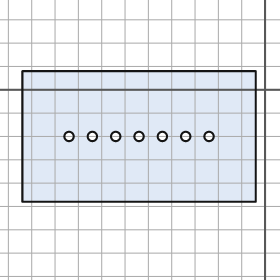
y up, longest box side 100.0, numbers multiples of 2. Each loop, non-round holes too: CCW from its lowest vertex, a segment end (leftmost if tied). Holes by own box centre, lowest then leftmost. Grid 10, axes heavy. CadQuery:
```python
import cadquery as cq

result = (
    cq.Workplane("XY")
    .moveTo(-104.0, -48.0)
    .lineTo(-4.0, -48.0)
    .lineTo(-4.0, 8.0)
    .lineTo(-104.0, 8.0)
    .close()
    .moveTo(-84.0, -20.0)
    .circle(2.0)
    .moveTo(-74.0, -20.0)
    .circle(2.0)
    .moveTo(-64.0, -20.0)
    .circle(2.0)
    .moveTo(-54.0, -20.0)
    .circle(2.0)
    .moveTo(-44.0, -20.0)
    .circle(2.0)
    .moveTo(-34.0, -20.0)
    .circle(2.0)
    .moveTo(-24.0, -20.0)
    .circle(2.0)
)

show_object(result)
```